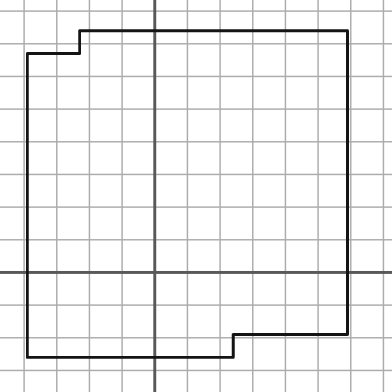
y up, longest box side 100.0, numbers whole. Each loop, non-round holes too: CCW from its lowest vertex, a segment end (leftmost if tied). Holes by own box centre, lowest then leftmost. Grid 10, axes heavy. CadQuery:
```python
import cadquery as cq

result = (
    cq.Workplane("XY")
    .moveTo(-39.0, -26.0)
    .lineTo(24.0, -26.0)
    .lineTo(24.0, -19.0)
    .lineTo(59.0, -19.0)
    .lineTo(59.0, 74.0)
    .lineTo(-23.0, 74.0)
    .lineTo(-23.0, 67.0)
    .lineTo(-39.0, 67.0)
    .close()
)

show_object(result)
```